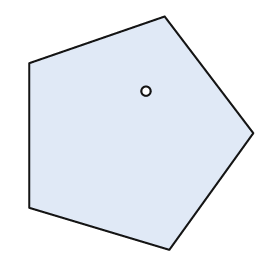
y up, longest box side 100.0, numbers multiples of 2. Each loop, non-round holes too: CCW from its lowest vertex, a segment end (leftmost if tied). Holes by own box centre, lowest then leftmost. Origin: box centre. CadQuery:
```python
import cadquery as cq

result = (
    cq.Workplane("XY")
    .moveTo(12.0, -50.0)
    .lineTo(48.0, 0.0)
    .lineTo(10.0, 50.0)
    .lineTo(-48.0, 30.0)
    .lineTo(-48.0, -32.0)
    .close()
    .moveTo(2.0, 18.0)
    .circle(2.0)
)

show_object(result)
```